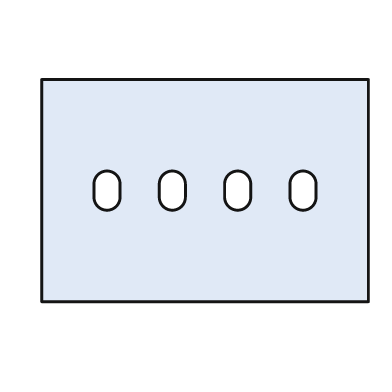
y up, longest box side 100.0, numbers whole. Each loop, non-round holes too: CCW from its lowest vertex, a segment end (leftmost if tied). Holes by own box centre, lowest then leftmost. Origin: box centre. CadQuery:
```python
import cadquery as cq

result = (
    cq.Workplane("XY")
    .moveTo(-50.0, -34.0)
    .lineTo(50.0, -34.0)
    .lineTo(50.0, 34.0)
    .lineTo(-50.0, 34.0)
    .close()
    .moveTo(-34.0, -2.0)
    .threePointArc((-30.0, -6.0), (-26.0, -2.0))
    .lineTo(-26.0, 2.0)
    .threePointArc((-30.0, 6.0), (-34.0, 2.0))
    .close()
    .moveTo(-14.0, -2.0)
    .threePointArc((-10.0, -6.0), (-6.0, -2.0))
    .lineTo(-6.0, 2.0)
    .threePointArc((-10.0, 6.0), (-14.0, 2.0))
    .close()
    .moveTo(6.0, -2.0)
    .threePointArc((10.0, -6.0), (14.0, -2.0))
    .lineTo(14.0, 2.0)
    .threePointArc((10.0, 6.0), (6.0, 2.0))
    .close()
    .moveTo(26.0, -2.0)
    .threePointArc((30.0, -6.0), (34.0, -2.0))
    .lineTo(34.0, 2.0)
    .threePointArc((30.0, 6.0), (26.0, 2.0))
    .close()
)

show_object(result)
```